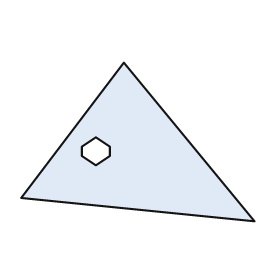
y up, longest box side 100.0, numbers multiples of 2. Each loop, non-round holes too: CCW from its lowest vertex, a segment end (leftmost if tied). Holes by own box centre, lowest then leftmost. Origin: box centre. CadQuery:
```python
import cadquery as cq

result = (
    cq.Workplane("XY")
    .moveTo(50.0, -34.0)
    .lineTo(-6.0, 34.0)
    .lineTo(-50.0, -24.0)
    .close()
    .moveTo(-18.0, -10.0)
    .lineTo(-12.0, -6.0)
    .lineTo(-12.0, -2.0)
    .lineTo(-18.0, 2.0)
    .lineTo(-24.0, -2.0)
    .lineTo(-24.0, -6.0)
    .close()
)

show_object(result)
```